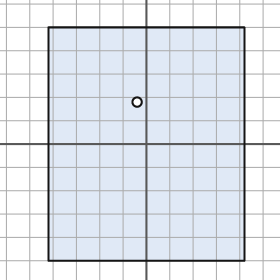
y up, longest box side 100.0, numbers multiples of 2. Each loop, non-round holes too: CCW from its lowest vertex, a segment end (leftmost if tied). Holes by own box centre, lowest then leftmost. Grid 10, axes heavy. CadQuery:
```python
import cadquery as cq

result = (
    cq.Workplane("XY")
    .moveTo(-42.0, -50.0)
    .lineTo(42.0, -50.0)
    .lineTo(42.0, 50.0)
    .lineTo(-42.0, 50.0)
    .close()
    .moveTo(-4.0, 18.0)
    .circle(2.0)
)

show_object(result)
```